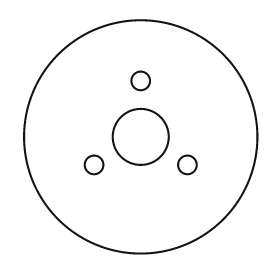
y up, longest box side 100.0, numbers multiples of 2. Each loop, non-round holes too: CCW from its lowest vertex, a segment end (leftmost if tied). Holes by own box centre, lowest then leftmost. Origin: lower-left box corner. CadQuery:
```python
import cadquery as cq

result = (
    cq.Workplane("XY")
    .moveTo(50.0, 50.0)
    .circle(50.0)
    .moveTo(30.0, 38.0)
    .circle(4.0)
    .moveTo(70.0, 38.0)
    .circle(4.0)
    .moveTo(50.0, 50.0)
    .circle(12.0)
    .moveTo(50.0, 74.0)
    .circle(4.0)
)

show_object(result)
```